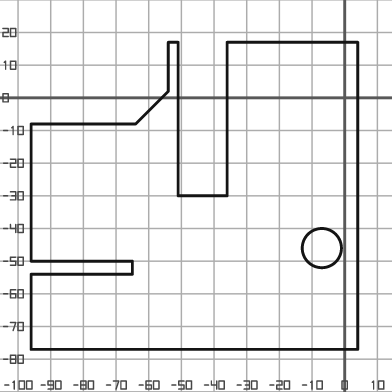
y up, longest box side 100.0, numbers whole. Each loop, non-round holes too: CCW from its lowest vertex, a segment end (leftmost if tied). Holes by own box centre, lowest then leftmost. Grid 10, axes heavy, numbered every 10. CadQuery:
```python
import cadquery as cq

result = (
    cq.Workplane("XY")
    .moveTo(-96.0, -77.0)
    .lineTo(4.0, -77.0)
    .lineTo(4.0, 17.0)
    .lineTo(-36.0, 17.0)
    .lineTo(-36.0, -30.0)
    .lineTo(-51.0, -30.0)
    .lineTo(-51.0, 17.0)
    .lineTo(-54.0, 17.0)
    .lineTo(-54.0, 2.0)
    .lineTo(-64.0, -8.0)
    .lineTo(-96.0, -8.0)
    .lineTo(-96.0, -50.0)
    .lineTo(-65.0, -50.0)
    .lineTo(-65.0, -54.0)
    .lineTo(-96.0, -54.0)
    .close()
    .moveTo(-7.0, -46.0)
    .circle(6.0)
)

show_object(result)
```